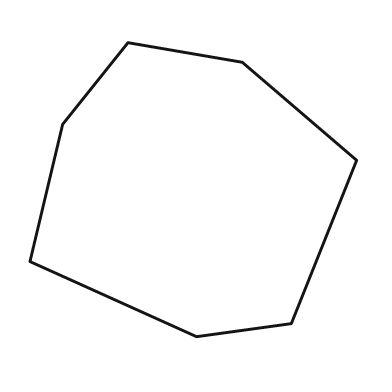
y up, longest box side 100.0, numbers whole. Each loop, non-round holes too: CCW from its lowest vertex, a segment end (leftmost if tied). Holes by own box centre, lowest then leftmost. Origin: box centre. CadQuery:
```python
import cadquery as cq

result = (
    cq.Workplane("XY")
    .moveTo(1.0, -45.0)
    .lineTo(30.0, -41.0)
    .lineTo(50.0, 9.0)
    .lineTo(15.0, 39.0)
    .lineTo(-20.0, 45.0)
    .lineTo(-40.0, 20.0)
    .lineTo(-50.0, -22.0)
    .close()
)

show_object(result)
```